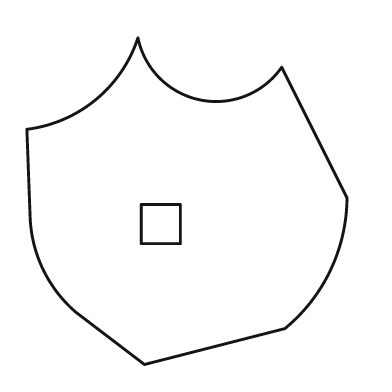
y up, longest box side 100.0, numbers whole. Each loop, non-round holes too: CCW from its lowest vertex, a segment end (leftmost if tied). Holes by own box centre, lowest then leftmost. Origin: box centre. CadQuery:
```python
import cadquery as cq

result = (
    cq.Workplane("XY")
    .moveTo(-13.0, -50.0)
    .lineTo(30.0, -39.0)
    .threePointArc((44.0, -21.0), (49.0, 1.0))
    .lineTo(29.0, 41.0)
    .threePointArc((4.0, 31.0), (-15.0, 50.0))
    .threePointArc((-28.0, 31.0), (-49.0, 22.0))
    .lineTo(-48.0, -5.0)
    .threePointArc((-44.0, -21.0), (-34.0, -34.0))
    .close()
    .moveTo(-14.0, -13.0)
    .lineTo(-2.0, -13.0)
    .lineTo(-2.0, -1.0)
    .lineTo(-14.0, -1.0)
    .close()
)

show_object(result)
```